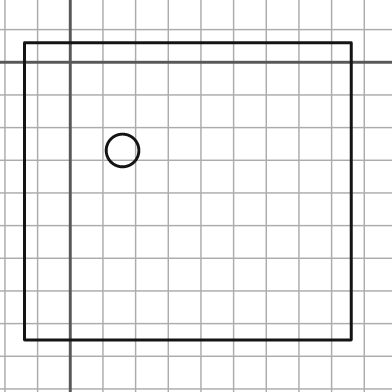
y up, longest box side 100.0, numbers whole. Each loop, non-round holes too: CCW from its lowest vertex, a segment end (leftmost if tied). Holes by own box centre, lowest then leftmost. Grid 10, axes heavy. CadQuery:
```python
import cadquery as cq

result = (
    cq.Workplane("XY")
    .moveTo(-14.0, -85.0)
    .lineTo(86.0, -85.0)
    .lineTo(86.0, 6.0)
    .lineTo(-14.0, 6.0)
    .close()
    .moveTo(16.0, -27.0)
    .circle(5.0)
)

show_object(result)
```